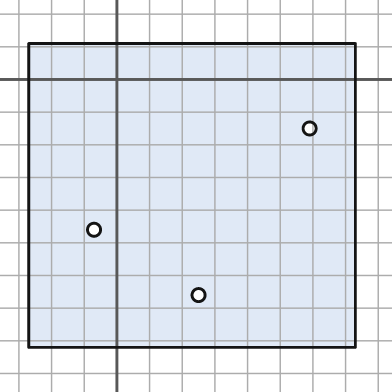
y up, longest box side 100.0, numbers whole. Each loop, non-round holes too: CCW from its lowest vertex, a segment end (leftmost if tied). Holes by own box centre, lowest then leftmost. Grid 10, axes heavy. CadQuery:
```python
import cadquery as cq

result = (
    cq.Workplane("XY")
    .moveTo(-27.0, -82.0)
    .lineTo(73.0, -82.0)
    .lineTo(73.0, 11.0)
    .lineTo(-27.0, 11.0)
    .close()
    .moveTo(25.0, -66.0)
    .circle(2.0)
    .moveTo(-7.0, -46.0)
    .circle(2.0)
    .moveTo(59.0, -15.0)
    .circle(2.0)
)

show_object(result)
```